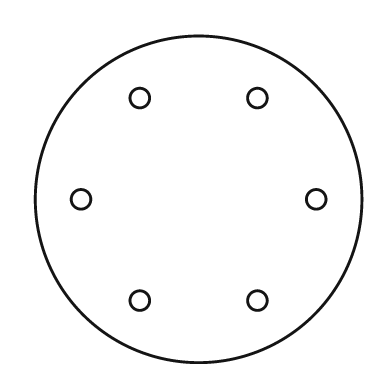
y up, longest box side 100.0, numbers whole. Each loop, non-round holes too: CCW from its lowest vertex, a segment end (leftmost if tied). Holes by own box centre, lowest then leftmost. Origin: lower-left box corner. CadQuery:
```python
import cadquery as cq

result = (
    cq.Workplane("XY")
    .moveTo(50.0, 50.0)
    .circle(50.0)
    .moveTo(32.0, 19.0)
    .circle(3.0)
    .moveTo(68.0, 19.0)
    .circle(3.0)
    .moveTo(14.0, 50.0)
    .circle(3.0)
    .moveTo(86.0, 50.0)
    .circle(3.0)
    .moveTo(32.0, 81.0)
    .circle(3.0)
    .moveTo(68.0, 81.0)
    .circle(3.0)
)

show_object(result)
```